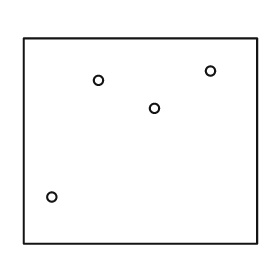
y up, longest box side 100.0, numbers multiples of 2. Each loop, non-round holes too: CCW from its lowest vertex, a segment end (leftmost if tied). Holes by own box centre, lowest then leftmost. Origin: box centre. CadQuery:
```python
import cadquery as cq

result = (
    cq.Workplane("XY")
    .moveTo(-50.0, -44.0)
    .lineTo(50.0, -44.0)
    .lineTo(50.0, 44.0)
    .lineTo(-50.0, 44.0)
    .close()
    .moveTo(-38.0, -24.0)
    .circle(2.0)
    .moveTo(6.0, 14.0)
    .circle(2.0)
    .moveTo(-18.0, 26.0)
    .circle(2.0)
    .moveTo(30.0, 30.0)
    .circle(2.0)
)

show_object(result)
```